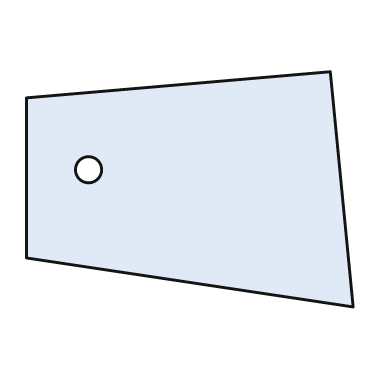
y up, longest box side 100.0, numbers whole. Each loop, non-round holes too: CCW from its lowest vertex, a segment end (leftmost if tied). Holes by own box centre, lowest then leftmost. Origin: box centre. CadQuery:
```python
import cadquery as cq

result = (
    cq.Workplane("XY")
    .moveTo(50.0, -36.0)
    .lineTo(43.0, 36.0)
    .lineTo(-50.0, 28.0)
    .lineTo(-50.0, -21.0)
    .close()
    .moveTo(-31.0, 6.0)
    .circle(4.0)
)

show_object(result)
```